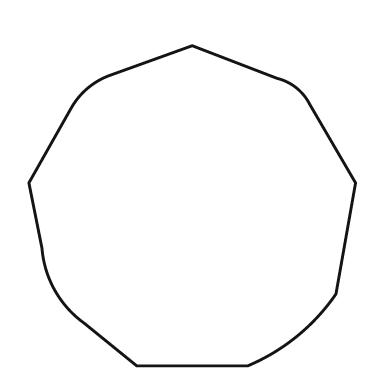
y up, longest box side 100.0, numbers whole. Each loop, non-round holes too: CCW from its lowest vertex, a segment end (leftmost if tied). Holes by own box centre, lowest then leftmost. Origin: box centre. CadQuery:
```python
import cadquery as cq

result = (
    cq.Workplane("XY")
    .moveTo(-17.0, -49.0)
    .lineTo(17.0, -49.0)
    .threePointArc((32.0, -40.0), (44.0, -27.0))
    .lineTo(50.0, 7.0)
    .lineTo(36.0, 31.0)
    .threePointArc((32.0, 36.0), (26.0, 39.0))
    .lineTo(0.0, 49.0)
    .lineTo(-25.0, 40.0)
    .threePointArc((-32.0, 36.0), (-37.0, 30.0))
    .lineTo(-50.0, 7.0)
    .lineTo(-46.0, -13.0)
    .threePointArc((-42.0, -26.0), (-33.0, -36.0))
    .close()
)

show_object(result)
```